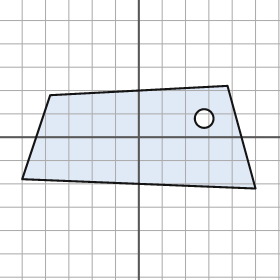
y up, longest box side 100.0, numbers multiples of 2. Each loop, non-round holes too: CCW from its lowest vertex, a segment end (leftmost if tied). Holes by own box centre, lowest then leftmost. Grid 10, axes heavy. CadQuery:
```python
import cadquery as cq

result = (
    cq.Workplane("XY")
    .moveTo(50.0, -22.0)
    .lineTo(38.0, 22.0)
    .lineTo(-38.0, 18.0)
    .lineTo(-50.0, -18.0)
    .close()
    .moveTo(28.0, 8.0)
    .circle(4.0)
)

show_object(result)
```